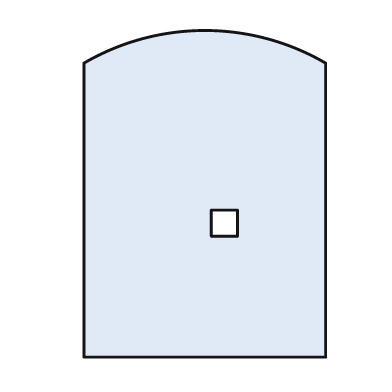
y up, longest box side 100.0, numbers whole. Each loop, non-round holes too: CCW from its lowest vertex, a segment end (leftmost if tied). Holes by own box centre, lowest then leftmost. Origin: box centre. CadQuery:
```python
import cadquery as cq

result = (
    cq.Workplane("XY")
    .moveTo(-37.0, -50.0)
    .lineTo(37.0, -50.0)
    .lineTo(37.0, 40.0)
    .threePointArc((0.0, 50.0), (-37.0, 40.0))
    .close()
    .moveTo(2.0, -13.0)
    .lineTo(10.0, -13.0)
    .lineTo(10.0, -5.0)
    .lineTo(2.0, -5.0)
    .close()
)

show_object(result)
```